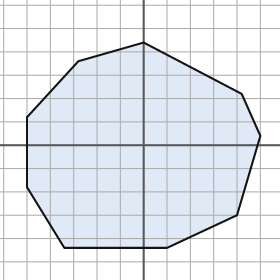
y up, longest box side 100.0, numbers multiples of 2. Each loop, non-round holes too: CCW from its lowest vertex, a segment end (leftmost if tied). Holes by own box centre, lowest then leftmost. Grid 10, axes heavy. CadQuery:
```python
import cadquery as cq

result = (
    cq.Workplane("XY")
    .moveTo(-34.0, -44.0)
    .lineTo(10.0, -44.0)
    .lineTo(40.0, -30.0)
    .lineTo(50.0, 4.0)
    .lineTo(42.0, 22.0)
    .lineTo(0.0, 44.0)
    .lineTo(-28.0, 36.0)
    .lineTo(-50.0, 12.0)
    .lineTo(-50.0, -18.0)
    .close()
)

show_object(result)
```